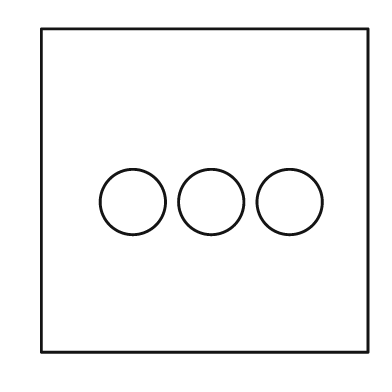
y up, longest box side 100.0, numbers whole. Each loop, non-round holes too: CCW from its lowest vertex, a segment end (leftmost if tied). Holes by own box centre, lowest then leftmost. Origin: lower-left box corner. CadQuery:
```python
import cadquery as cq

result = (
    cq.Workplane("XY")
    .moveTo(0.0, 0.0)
    .lineTo(100.0, 0.0)
    .lineTo(100.0, 99.0)
    .lineTo(0.0, 99.0)
    .close()
    .moveTo(28.0, 46.0)
    .circle(10.0)
    .moveTo(52.0, 46.0)
    .circle(10.0)
    .moveTo(76.0, 46.0)
    .circle(10.0)
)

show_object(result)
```